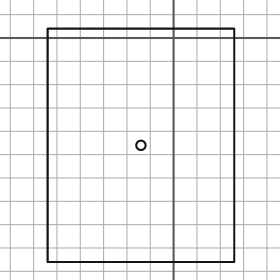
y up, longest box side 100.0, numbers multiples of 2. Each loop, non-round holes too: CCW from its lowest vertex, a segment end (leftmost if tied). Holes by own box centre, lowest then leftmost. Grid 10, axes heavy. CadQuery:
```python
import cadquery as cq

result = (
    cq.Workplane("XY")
    .moveTo(-54.0, -96.0)
    .lineTo(26.0, -96.0)
    .lineTo(26.0, 4.0)
    .lineTo(-54.0, 4.0)
    .close()
    .moveTo(-14.0, -46.0)
    .circle(2.0)
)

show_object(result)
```